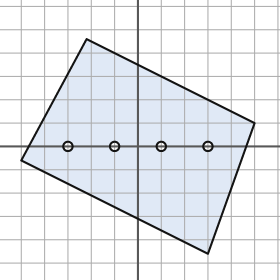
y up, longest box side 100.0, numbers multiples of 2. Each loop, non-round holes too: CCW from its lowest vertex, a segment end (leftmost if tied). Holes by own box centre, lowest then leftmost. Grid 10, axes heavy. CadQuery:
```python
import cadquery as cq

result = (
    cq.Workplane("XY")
    .moveTo(30.0, -46.0)
    .lineTo(50.0, 10.0)
    .lineTo(-22.0, 46.0)
    .lineTo(-50.0, -6.0)
    .close()
    .moveTo(-30.0, 0.0)
    .circle(2.0)
    .moveTo(-10.0, 0.0)
    .circle(2.0)
    .moveTo(10.0, 0.0)
    .circle(2.0)
    .moveTo(30.0, 0.0)
    .circle(2.0)
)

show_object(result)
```